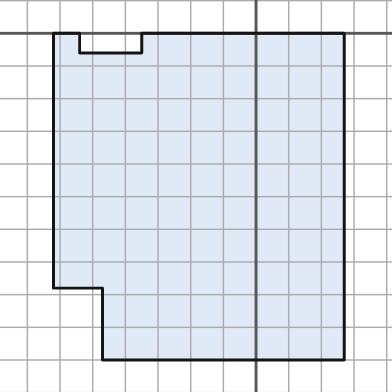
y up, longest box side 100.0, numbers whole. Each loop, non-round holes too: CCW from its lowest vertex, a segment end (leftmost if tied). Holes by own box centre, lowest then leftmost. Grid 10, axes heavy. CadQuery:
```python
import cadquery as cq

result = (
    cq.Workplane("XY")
    .moveTo(-47.0, -100.0)
    .lineTo(27.0, -100.0)
    .lineTo(27.0, 0.0)
    .lineTo(-35.0, 0.0)
    .lineTo(-35.0, -6.0)
    .lineTo(-54.0, -6.0)
    .lineTo(-54.0, 0.0)
    .lineTo(-62.0, 0.0)
    .lineTo(-62.0, -78.0)
    .lineTo(-47.0, -78.0)
    .close()
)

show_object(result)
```